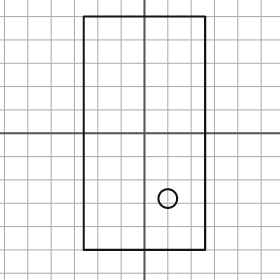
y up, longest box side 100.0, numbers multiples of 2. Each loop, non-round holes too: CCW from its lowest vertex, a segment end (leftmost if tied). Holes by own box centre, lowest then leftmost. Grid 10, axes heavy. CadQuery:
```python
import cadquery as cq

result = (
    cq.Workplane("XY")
    .moveTo(-26.0, -50.0)
    .lineTo(26.0, -50.0)
    .lineTo(26.0, 50.0)
    .lineTo(-26.0, 50.0)
    .close()
    .moveTo(10.0, -28.0)
    .circle(4.0)
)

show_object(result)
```